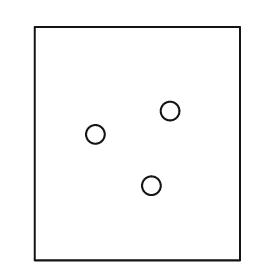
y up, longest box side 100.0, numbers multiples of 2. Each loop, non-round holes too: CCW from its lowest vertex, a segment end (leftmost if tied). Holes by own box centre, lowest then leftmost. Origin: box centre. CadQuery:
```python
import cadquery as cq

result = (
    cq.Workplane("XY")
    .moveTo(-44.0, -50.0)
    .lineTo(44.0, -50.0)
    .lineTo(44.0, 50.0)
    .lineTo(-44.0, 50.0)
    .close()
    .moveTo(6.0, -18.0)
    .circle(4.0)
    .moveTo(-18.0, 4.0)
    .circle(4.0)
    .moveTo(14.0, 14.0)
    .circle(4.0)
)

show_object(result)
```